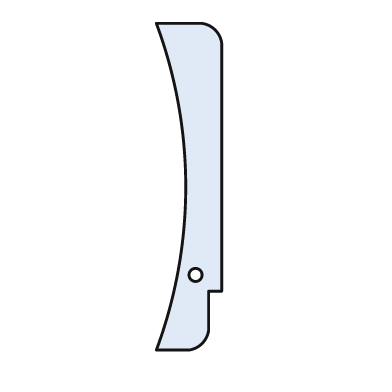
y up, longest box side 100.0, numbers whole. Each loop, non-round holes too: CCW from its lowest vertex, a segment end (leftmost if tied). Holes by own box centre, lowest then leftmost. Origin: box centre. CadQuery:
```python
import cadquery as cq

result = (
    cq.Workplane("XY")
    .moveTo(-10.0, -50.0)
    .lineTo(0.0, -50.0)
    .threePointArc((4.0, -48.0), (6.0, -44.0))
    .lineTo(6.0, -32.0)
    .lineTo(10.0, -32.0)
    .lineTo(10.0, 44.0)
    .threePointArc((8.0, 48.0), (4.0, 50.0))
    .lineTo(-10.0, 50.0)
    .threePointArc((-1.0, 0.0), (-10.0, -50.0))
    .close()
    .moveTo(2.0, -27.0)
    .circle(2.0)
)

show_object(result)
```